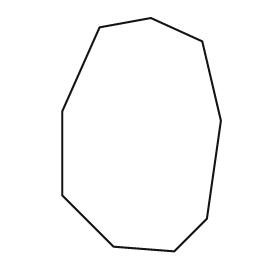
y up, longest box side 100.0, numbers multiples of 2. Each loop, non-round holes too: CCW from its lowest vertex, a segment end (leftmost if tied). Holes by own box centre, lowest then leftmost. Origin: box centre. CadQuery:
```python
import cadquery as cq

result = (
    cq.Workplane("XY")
    .moveTo(14.0, -50.0)
    .lineTo(28.0, -36.0)
    .lineTo(34.0, 6.0)
    .lineTo(26.0, 40.0)
    .lineTo(4.0, 50.0)
    .lineTo(-18.0, 46.0)
    .lineTo(-34.0, 10.0)
    .lineTo(-34.0, -26.0)
    .lineTo(-12.0, -48.0)
    .close()
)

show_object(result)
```